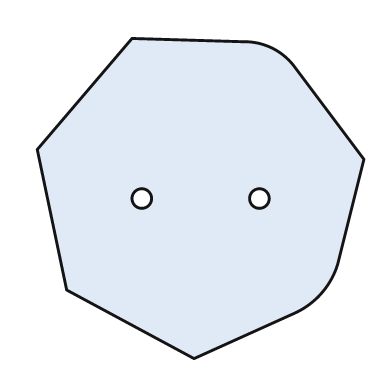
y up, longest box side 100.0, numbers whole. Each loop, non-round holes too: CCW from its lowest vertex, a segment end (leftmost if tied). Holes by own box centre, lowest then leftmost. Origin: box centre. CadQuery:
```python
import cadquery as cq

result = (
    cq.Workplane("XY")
    .moveTo(-2.0, -49.0)
    .lineTo(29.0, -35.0)
    .threePointArc((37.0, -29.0), (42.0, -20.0))
    .lineTo(50.0, 12.0)
    .lineTo(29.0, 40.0)
    .threePointArc((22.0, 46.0), (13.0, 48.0))
    .lineTo(-21.0, 49.0)
    .lineTo(-50.0, 15.0)
    .lineTo(-41.0, -28.0)
    .close()
    .moveTo(-18.0, 0.0)
    .circle(3.0)
    .moveTo(18.0, 0.0)
    .circle(3.0)
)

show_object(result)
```